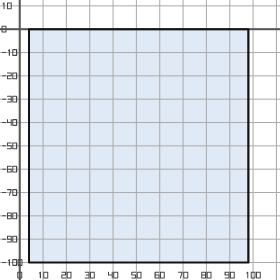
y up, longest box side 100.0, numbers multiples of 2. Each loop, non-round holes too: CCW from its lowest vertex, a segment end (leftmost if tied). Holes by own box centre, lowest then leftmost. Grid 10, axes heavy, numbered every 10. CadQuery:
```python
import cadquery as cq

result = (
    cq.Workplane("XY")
    .moveTo(4.0, -100.0)
    .lineTo(98.0, -100.0)
    .lineTo(98.0, 0.0)
    .lineTo(4.0, 0.0)
    .close()
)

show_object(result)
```